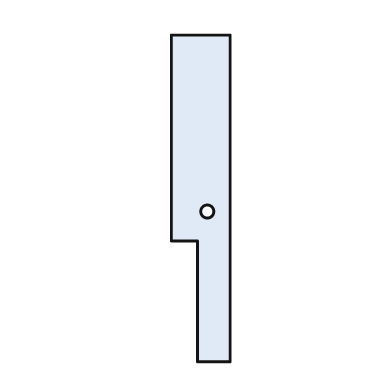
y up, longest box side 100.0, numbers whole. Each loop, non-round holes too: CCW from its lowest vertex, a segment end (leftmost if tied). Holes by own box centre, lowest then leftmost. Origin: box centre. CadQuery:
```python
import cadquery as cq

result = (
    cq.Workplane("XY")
    .moveTo(-1.0, -50.0)
    .lineTo(9.0, -50.0)
    .lineTo(9.0, 50.0)
    .lineTo(-9.0, 50.0)
    .lineTo(-9.0, -13.0)
    .lineTo(-1.0, -13.0)
    .close()
    .moveTo(2.0, -4.0)
    .circle(2.0)
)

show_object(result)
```